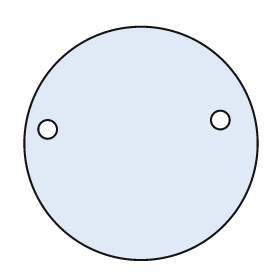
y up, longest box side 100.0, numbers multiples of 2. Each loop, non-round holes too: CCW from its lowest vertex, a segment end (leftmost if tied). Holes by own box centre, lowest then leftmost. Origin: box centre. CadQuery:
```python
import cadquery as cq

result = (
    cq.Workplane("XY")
    .moveTo(0.0, 0.0)
    .circle(50.0)
    .moveTo(-40.0, 6.0)
    .circle(4.0)
    .moveTo(34.0, 10.0)
    .circle(4.0)
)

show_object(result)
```